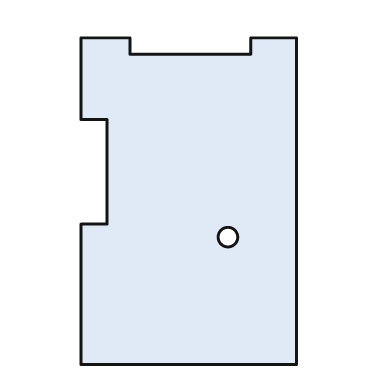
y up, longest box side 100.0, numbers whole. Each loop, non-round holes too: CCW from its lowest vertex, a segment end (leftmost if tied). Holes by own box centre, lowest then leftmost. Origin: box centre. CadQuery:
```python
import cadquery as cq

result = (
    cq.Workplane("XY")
    .moveTo(-33.0, -50.0)
    .lineTo(33.0, -50.0)
    .lineTo(33.0, 50.0)
    .lineTo(19.0, 50.0)
    .lineTo(19.0, 45.0)
    .lineTo(-18.0, 45.0)
    .lineTo(-18.0, 50.0)
    .lineTo(-33.0, 50.0)
    .lineTo(-33.0, 25.0)
    .lineTo(-25.0, 25.0)
    .lineTo(-25.0, -7.0)
    .lineTo(-33.0, -7.0)
    .close()
    .moveTo(12.0, -11.0)
    .circle(3.0)
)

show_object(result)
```